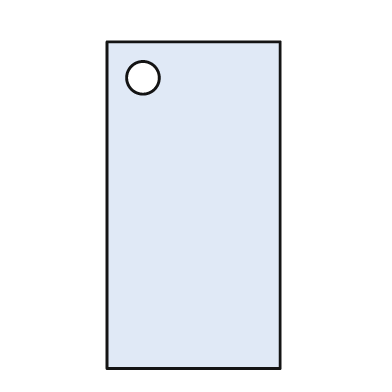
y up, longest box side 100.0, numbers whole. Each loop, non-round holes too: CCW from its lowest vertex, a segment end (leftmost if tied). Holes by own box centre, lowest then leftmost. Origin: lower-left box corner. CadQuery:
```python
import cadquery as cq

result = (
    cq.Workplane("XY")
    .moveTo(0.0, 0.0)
    .lineTo(53.0, 0.0)
    .lineTo(53.0, 100.0)
    .lineTo(0.0, 100.0)
    .close()
    .moveTo(11.0, 89.0)
    .circle(5.0)
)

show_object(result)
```